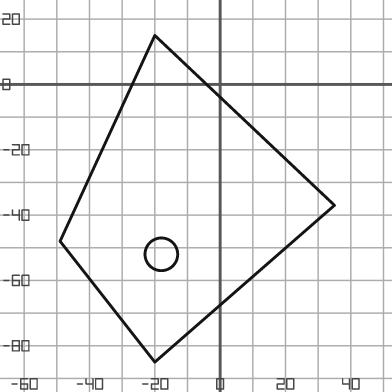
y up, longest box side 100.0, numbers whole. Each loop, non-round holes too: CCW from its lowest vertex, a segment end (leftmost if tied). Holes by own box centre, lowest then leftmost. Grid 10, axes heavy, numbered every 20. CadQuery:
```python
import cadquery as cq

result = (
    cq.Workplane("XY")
    .moveTo(-20.0, -85.0)
    .lineTo(35.0, -37.0)
    .lineTo(-20.0, 15.0)
    .lineTo(-49.0, -48.0)
    .close()
    .moveTo(-18.0, -52.0)
    .circle(5.0)
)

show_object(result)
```